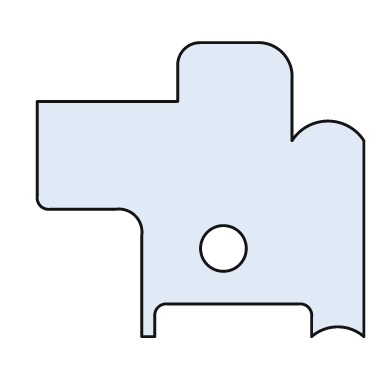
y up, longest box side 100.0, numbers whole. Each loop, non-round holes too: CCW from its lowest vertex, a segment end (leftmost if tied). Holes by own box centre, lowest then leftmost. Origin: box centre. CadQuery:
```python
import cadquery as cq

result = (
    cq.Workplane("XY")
    .moveTo(-18.0, -45.0)
    .lineTo(-14.0, -45.0)
    .lineTo(-14.0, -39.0)
    .threePointArc((-13.0, -36.0), (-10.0, -35.0))
    .lineTo(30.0, -35.0)
    .threePointArc((33.0, -36.0), (34.0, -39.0))
    .lineTo(34.0, -45.0)
    .threePointArc((42.0, -42.0), (50.0, -45.0))
    .lineTo(50.0, 15.0)
    .threePointArc((39.0, 21.0), (28.0, 15.0))
    .lineTo(28.0, 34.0)
    .threePointArc((25.0, 42.0), (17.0, 45.0))
    .lineTo(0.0, 45.0)
    .threePointArc((-5.0, 43.0), (-7.0, 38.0))
    .lineTo(-7.0, 27.0)
    .lineTo(-50.0, 27.0)
    .lineTo(-50.0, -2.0)
    .threePointArc((-49.0, -5.0), (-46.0, -6.0))
    .lineTo(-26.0, -6.0)
    .threePointArc((-20.0, -8.0), (-18.0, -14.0))
    .close()
    .moveTo(7.0, -18.0)
    .circle(7.0)
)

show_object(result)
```